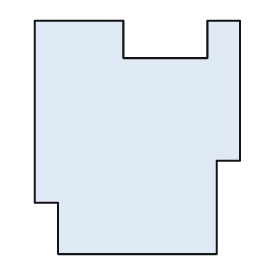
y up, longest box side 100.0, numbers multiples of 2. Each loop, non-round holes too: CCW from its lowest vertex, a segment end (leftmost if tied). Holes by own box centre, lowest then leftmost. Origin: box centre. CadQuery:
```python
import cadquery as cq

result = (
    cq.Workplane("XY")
    .moveTo(-34.0, -50.0)
    .lineTo(34.0, -50.0)
    .lineTo(34.0, -10.0)
    .lineTo(44.0, -10.0)
    .lineTo(44.0, 50.0)
    .lineTo(30.0, 50.0)
    .lineTo(30.0, 34.0)
    .lineTo(-6.0, 34.0)
    .lineTo(-6.0, 50.0)
    .lineTo(-44.0, 50.0)
    .lineTo(-44.0, -28.0)
    .lineTo(-34.0, -28.0)
    .close()
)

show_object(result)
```